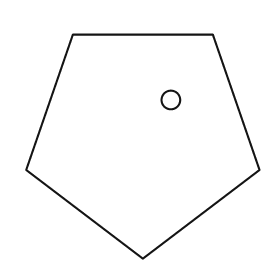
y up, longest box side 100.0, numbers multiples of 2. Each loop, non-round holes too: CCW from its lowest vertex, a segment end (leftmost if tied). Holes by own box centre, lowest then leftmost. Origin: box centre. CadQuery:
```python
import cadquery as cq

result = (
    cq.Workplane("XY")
    .moveTo(0.0, -48.0)
    .lineTo(50.0, -10.0)
    .lineTo(30.0, 48.0)
    .lineTo(-30.0, 48.0)
    .lineTo(-50.0, -10.0)
    .close()
    .moveTo(12.0, 20.0)
    .circle(4.0)
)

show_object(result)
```